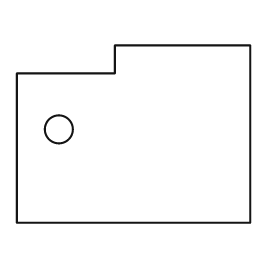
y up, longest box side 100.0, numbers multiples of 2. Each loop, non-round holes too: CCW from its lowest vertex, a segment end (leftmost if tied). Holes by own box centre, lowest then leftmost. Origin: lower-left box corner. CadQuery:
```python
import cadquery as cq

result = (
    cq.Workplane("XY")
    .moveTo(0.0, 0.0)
    .lineTo(100.0, 0.0)
    .lineTo(100.0, 76.0)
    .lineTo(42.0, 76.0)
    .lineTo(42.0, 64.0)
    .lineTo(0.0, 64.0)
    .close()
    .moveTo(18.0, 40.0)
    .circle(6.0)
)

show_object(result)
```